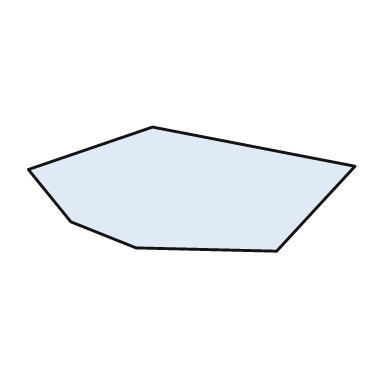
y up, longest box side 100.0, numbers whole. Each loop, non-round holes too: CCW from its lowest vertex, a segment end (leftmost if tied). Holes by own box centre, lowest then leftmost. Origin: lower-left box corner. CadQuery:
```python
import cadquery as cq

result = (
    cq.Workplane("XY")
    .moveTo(76.0, 0.0)
    .lineTo(100.0, 26.0)
    .lineTo(38.0, 38.0)
    .lineTo(0.0, 25.0)
    .lineTo(13.0, 9.0)
    .lineTo(33.0, 1.0)
    .close()
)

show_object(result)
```